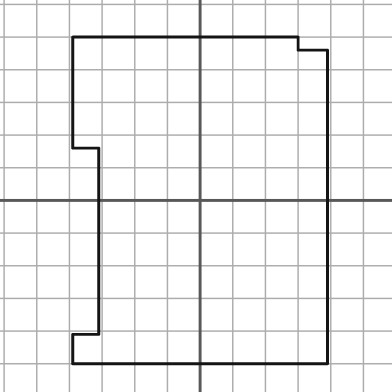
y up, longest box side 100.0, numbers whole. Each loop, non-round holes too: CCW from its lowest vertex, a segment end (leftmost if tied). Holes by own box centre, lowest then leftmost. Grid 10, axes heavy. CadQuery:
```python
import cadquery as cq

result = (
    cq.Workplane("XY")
    .moveTo(-39.0, -50.0)
    .lineTo(39.0, -50.0)
    .lineTo(39.0, 46.0)
    .lineTo(30.0, 46.0)
    .lineTo(30.0, 50.0)
    .lineTo(-39.0, 50.0)
    .lineTo(-39.0, 16.0)
    .lineTo(-31.0, 16.0)
    .lineTo(-31.0, -41.0)
    .lineTo(-39.0, -41.0)
    .close()
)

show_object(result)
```